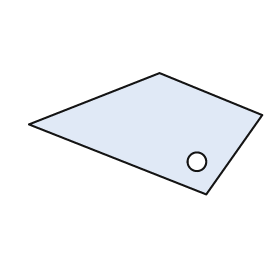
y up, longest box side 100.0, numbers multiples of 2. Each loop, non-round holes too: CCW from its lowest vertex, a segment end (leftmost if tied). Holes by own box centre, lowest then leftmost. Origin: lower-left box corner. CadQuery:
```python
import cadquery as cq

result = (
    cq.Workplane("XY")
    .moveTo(76.0, 0.0)
    .lineTo(100.0, 34.0)
    .lineTo(56.0, 52.0)
    .lineTo(0.0, 30.0)
    .close()
    .moveTo(72.0, 14.0)
    .circle(4.0)
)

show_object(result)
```